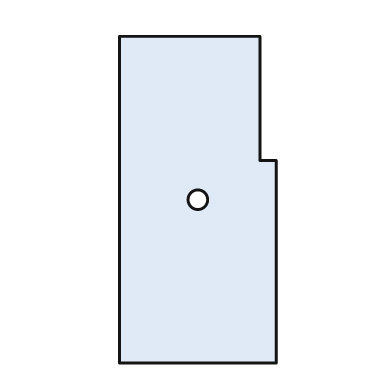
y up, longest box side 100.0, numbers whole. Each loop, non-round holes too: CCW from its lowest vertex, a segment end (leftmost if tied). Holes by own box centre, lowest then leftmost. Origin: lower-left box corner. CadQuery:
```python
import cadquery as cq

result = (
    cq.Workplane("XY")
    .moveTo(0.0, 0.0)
    .lineTo(48.0, 0.0)
    .lineTo(48.0, 62.0)
    .lineTo(43.0, 62.0)
    .lineTo(43.0, 100.0)
    .lineTo(0.0, 100.0)
    .close()
    .moveTo(24.0, 50.0)
    .circle(3.0)
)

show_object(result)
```